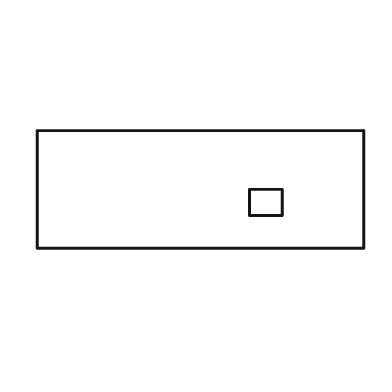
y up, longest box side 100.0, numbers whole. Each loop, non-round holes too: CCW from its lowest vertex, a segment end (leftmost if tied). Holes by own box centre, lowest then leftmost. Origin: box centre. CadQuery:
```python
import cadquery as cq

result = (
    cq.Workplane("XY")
    .moveTo(-50.0, -18.0)
    .lineTo(50.0, -18.0)
    .lineTo(50.0, 18.0)
    .lineTo(-50.0, 18.0)
    .close()
    .moveTo(15.0, -8.0)
    .lineTo(25.0, -8.0)
    .lineTo(25.0, 0.0)
    .lineTo(15.0, 0.0)
    .close()
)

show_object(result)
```